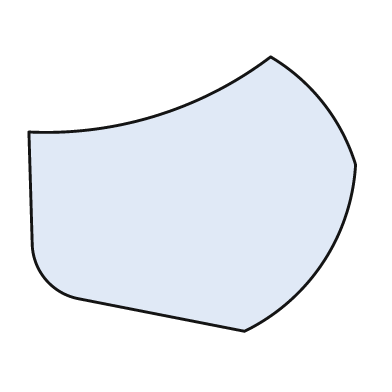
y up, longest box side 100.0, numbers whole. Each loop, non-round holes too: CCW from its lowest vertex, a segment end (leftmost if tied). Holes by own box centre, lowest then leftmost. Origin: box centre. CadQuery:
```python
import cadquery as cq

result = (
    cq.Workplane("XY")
    .moveTo(16.0, -42.0)
    .threePointArc((40.0, -21.0), (50.0, 9.0))
    .threePointArc((40.0, 28.0), (24.0, 42.0))
    .threePointArc((-11.0, 24.0), (-50.0, 19.0))
    .lineTo(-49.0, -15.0)
    .threePointArc((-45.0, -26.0), (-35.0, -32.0))
    .close()
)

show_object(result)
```